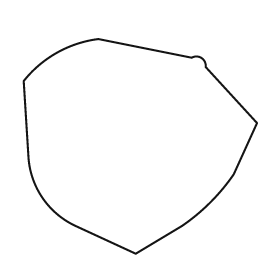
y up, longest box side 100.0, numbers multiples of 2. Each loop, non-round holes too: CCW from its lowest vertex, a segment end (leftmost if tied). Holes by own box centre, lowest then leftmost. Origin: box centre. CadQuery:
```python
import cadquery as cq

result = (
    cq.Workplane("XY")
    .moveTo(-2.0, -46.0)
    .lineTo(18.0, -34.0)
    .threePointArc((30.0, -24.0), (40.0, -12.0))
    .lineTo(50.0, 10.0)
    .lineTo(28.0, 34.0)
    .threePointArc((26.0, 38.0), (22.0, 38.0))
    .lineTo(-18.0, 46.0)
    .threePointArc((-36.0, 40.0), (-50.0, 28.0))
    .lineTo(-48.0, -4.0)
    .threePointArc((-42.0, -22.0), (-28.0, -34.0))
    .close()
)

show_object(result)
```